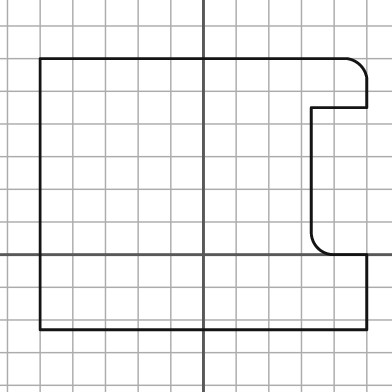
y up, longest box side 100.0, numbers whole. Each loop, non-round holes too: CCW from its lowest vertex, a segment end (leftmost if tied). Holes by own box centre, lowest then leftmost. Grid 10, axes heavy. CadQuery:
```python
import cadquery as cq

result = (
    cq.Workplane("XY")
    .moveTo(-50.0, -23.0)
    .lineTo(50.0, -23.0)
    .lineTo(50.0, 0.0)
    .lineTo(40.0, 0.0)
    .threePointArc((35.0, 2.0), (33.0, 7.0))
    .lineTo(33.0, 45.0)
    .lineTo(50.0, 45.0)
    .lineTo(50.0, 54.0)
    .threePointArc((48.0, 58.0), (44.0, 60.0))
    .lineTo(-50.0, 60.0)
    .close()
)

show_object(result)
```